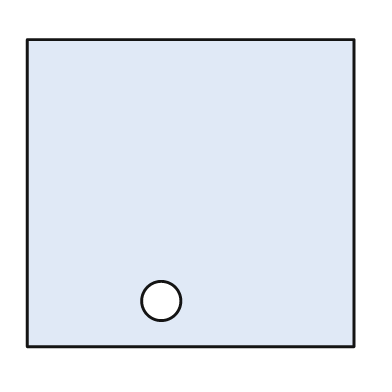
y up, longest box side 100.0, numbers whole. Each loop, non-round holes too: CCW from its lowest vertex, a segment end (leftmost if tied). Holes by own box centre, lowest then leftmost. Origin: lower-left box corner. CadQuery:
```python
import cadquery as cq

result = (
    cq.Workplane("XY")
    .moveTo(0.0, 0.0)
    .lineTo(100.0, 0.0)
    .lineTo(100.0, 94.0)
    .lineTo(0.0, 94.0)
    .close()
    .moveTo(41.0, 14.0)
    .circle(6.0)
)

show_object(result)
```